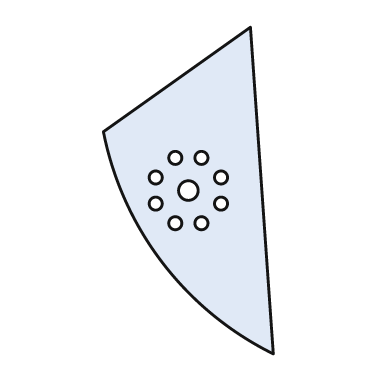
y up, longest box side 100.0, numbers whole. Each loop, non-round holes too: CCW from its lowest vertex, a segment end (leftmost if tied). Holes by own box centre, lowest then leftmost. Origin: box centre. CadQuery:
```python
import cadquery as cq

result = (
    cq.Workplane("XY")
    .moveTo(26.0, -50.0)
    .lineTo(19.0, 50.0)
    .lineTo(-26.0, 18.0)
    .threePointArc((-8.0, -22.0), (26.0, -50.0))
    .close()
    .moveTo(-4.0, -10.0)
    .circle(2.0)
    .moveTo(4.0, -10.0)
    .circle(2.0)
    .moveTo(-10.0, -4.0)
    .circle(2.0)
    .moveTo(10.0, -4.0)
    .circle(2.0)
    .moveTo(0.0, 0.0)
    .circle(3.0)
    .moveTo(-10.0, 4.0)
    .circle(2.0)
    .moveTo(10.0, 4.0)
    .circle(2.0)
    .moveTo(-4.0, 10.0)
    .circle(2.0)
    .moveTo(4.0, 10.0)
    .circle(2.0)
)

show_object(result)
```